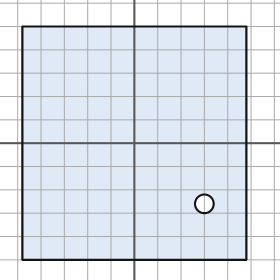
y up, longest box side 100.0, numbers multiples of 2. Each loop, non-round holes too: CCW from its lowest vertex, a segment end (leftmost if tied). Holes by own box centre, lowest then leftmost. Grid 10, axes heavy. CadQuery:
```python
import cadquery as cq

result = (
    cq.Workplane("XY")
    .moveTo(-48.0, -50.0)
    .lineTo(48.0, -50.0)
    .lineTo(48.0, 50.0)
    .lineTo(-48.0, 50.0)
    .close()
    .moveTo(30.0, -26.0)
    .circle(4.0)
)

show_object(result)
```